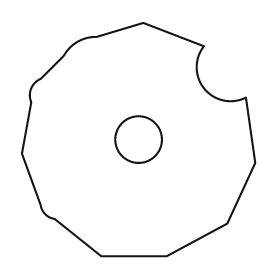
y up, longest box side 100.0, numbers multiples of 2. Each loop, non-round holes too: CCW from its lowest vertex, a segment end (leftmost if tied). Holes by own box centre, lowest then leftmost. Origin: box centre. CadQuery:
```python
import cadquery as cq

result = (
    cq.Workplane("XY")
    .moveTo(-16.0, -50.0)
    .lineTo(12.0, -50.0)
    .lineTo(38.0, -36.0)
    .lineTo(50.0, -10.0)
    .lineTo(46.0, 18.0)
    .threePointArc((28.0, 22.0), (28.0, 40.0))
    .lineTo(2.0, 50.0)
    .lineTo(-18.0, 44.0)
    .threePointArc((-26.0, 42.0), (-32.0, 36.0))
    .lineTo(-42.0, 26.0)
    .threePointArc((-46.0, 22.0), (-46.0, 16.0))
    .lineTo(-50.0, -6.0)
    .lineTo(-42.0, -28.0)
    .threePointArc((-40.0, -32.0), (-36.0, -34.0))
    .close()
    .moveTo(0.0, 0.0)
    .circle(10.0)
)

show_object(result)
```